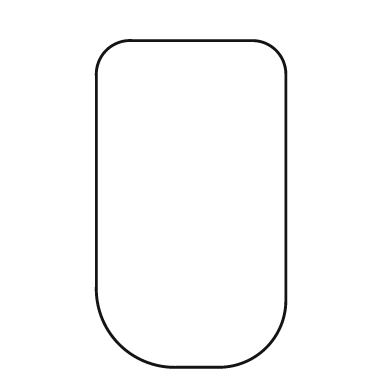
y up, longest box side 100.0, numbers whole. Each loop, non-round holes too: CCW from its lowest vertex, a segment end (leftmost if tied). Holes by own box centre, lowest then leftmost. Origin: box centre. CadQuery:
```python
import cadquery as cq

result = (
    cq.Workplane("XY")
    .moveTo(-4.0, -50.0)
    .lineTo(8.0, -50.0)
    .threePointArc((23.0, -44.0), (29.0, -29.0))
    .lineTo(29.0, 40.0)
    .threePointArc((26.0, 47.0), (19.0, 50.0))
    .lineTo(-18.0, 50.0)
    .threePointArc((-26.0, 47.0), (-29.0, 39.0))
    .lineTo(-29.0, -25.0)
    .threePointArc((-22.0, -43.0), (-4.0, -50.0))
    .close()
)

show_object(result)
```